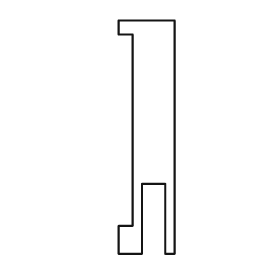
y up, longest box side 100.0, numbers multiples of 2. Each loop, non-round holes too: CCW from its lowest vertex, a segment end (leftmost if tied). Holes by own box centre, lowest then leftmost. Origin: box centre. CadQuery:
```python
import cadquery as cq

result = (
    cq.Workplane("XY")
    .moveTo(-12.0, -50.0)
    .lineTo(-2.0, -50.0)
    .lineTo(-2.0, -20.0)
    .lineTo(8.0, -20.0)
    .lineTo(8.0, -50.0)
    .lineTo(12.0, -50.0)
    .lineTo(12.0, 50.0)
    .lineTo(-12.0, 50.0)
    .lineTo(-12.0, 44.0)
    .lineTo(-6.0, 44.0)
    .lineTo(-6.0, -38.0)
    .lineTo(-12.0, -38.0)
    .close()
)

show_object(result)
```